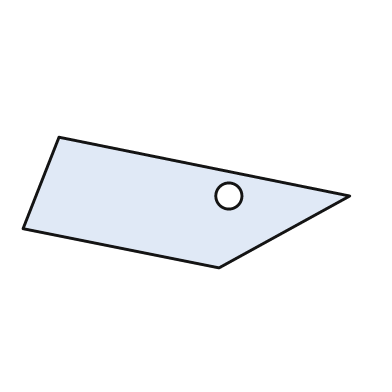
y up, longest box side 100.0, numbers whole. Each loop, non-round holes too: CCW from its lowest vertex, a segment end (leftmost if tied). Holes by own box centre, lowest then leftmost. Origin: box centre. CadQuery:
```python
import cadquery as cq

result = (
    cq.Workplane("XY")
    .moveTo(10.0, -20.0)
    .lineTo(50.0, 2.0)
    .lineTo(-39.0, 20.0)
    .lineTo(-50.0, -8.0)
    .close()
    .moveTo(13.0, 2.0)
    .circle(4.0)
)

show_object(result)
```